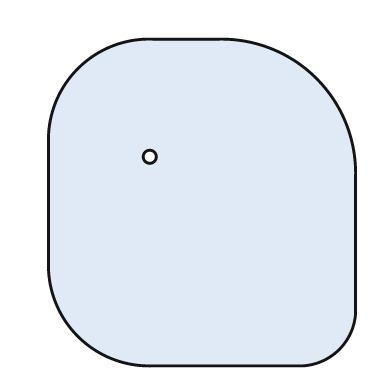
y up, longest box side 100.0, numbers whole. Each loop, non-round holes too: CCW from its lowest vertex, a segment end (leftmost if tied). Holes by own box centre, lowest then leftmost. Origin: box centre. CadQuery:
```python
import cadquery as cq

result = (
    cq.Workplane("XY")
    .moveTo(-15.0, -50.0)
    .lineTo(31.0, -50.0)
    .threePointArc((42.0, -45.0), (47.0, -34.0))
    .lineTo(47.0, 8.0)
    .threePointArc((35.0, 38.0), (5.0, 50.0))
    .lineTo(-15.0, 50.0)
    .threePointArc((-38.0, 41.0), (-47.0, 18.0))
    .lineTo(-47.0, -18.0)
    .threePointArc((-38.0, -41.0), (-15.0, -50.0))
    .close()
    .moveTo(-16.0, 14.0)
    .circle(2.0)
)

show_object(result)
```